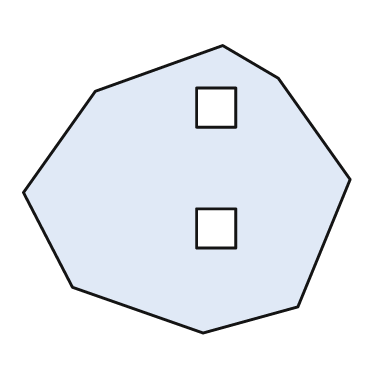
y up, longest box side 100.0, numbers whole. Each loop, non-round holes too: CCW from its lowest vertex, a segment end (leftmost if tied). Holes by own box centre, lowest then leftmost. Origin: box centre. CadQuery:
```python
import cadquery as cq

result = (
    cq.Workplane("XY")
    .moveTo(5.0, -44.0)
    .lineTo(34.0, -36.0)
    .lineTo(50.0, 3.0)
    .lineTo(28.0, 34.0)
    .lineTo(11.0, 44.0)
    .lineTo(-28.0, 30.0)
    .lineTo(-50.0, -1.0)
    .lineTo(-35.0, -30.0)
    .close()
    .moveTo(3.0, -18.0)
    .lineTo(15.0, -18.0)
    .lineTo(15.0, -6.0)
    .lineTo(3.0, -6.0)
    .close()
    .moveTo(3.0, 19.0)
    .lineTo(15.0, 19.0)
    .lineTo(15.0, 31.0)
    .lineTo(3.0, 31.0)
    .close()
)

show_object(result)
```